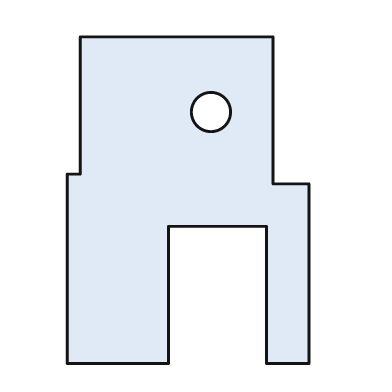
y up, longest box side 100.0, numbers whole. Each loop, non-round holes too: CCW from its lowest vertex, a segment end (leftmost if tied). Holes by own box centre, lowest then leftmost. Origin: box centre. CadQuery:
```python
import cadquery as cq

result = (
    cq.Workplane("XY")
    .moveTo(-37.0, -50.0)
    .lineTo(-6.0, -50.0)
    .lineTo(-6.0, -8.0)
    .lineTo(24.0, -8.0)
    .lineTo(24.0, -50.0)
    .lineTo(37.0, -50.0)
    .lineTo(37.0, 5.0)
    .lineTo(26.0, 5.0)
    .lineTo(26.0, 50.0)
    .lineTo(-33.0, 50.0)
    .lineTo(-33.0, 8.0)
    .lineTo(-37.0, 8.0)
    .close()
    .moveTo(7.0, 27.0)
    .circle(6.0)
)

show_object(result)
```